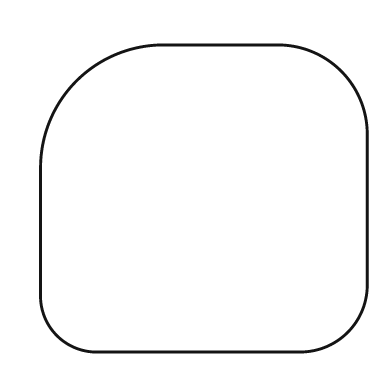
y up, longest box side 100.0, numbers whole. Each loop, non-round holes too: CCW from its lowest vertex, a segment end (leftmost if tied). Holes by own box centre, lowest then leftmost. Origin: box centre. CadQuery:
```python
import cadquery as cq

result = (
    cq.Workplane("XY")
    .moveTo(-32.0, -47.0)
    .lineTo(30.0, -47.0)
    .threePointArc((44.0, -41.0), (50.0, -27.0))
    .lineTo(50.0, 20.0)
    .threePointArc((42.0, 39.0), (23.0, 47.0))
    .lineTo(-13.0, 47.0)
    .threePointArc((-39.0, 36.0), (-50.0, 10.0))
    .lineTo(-50.0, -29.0)
    .threePointArc((-45.0, -42.0), (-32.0, -47.0))
    .close()
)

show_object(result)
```